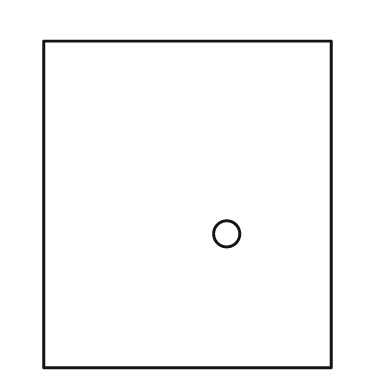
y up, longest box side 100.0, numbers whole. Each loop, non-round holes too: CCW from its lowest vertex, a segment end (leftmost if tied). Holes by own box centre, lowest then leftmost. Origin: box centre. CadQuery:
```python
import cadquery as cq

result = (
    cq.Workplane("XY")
    .moveTo(-44.0, -50.0)
    .lineTo(44.0, -50.0)
    .lineTo(44.0, 50.0)
    .lineTo(-44.0, 50.0)
    .close()
    .moveTo(12.0, -9.0)
    .circle(4.0)
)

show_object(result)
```